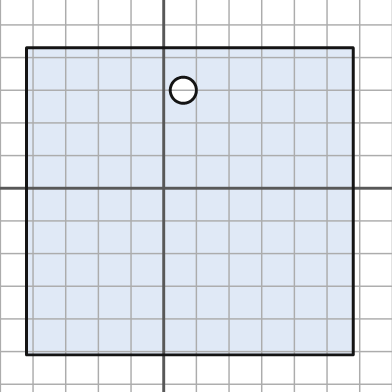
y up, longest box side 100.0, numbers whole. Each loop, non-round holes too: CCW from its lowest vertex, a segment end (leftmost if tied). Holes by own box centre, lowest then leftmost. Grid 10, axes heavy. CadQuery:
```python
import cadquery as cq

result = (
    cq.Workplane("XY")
    .moveTo(-42.0, -51.0)
    .lineTo(58.0, -51.0)
    .lineTo(58.0, 43.0)
    .lineTo(-42.0, 43.0)
    .close()
    .moveTo(6.0, 30.0)
    .circle(4.0)
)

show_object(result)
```